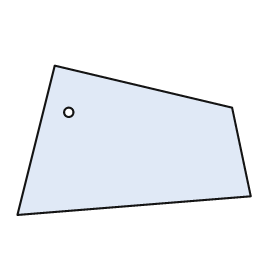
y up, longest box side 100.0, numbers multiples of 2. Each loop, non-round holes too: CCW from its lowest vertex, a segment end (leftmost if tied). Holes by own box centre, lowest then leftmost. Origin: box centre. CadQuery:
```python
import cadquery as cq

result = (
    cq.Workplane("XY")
    .moveTo(-50.0, -32.0)
    .lineTo(50.0, -24.0)
    .lineTo(42.0, 14.0)
    .lineTo(-34.0, 32.0)
    .close()
    .moveTo(-28.0, 12.0)
    .circle(2.0)
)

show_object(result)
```